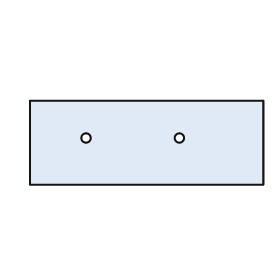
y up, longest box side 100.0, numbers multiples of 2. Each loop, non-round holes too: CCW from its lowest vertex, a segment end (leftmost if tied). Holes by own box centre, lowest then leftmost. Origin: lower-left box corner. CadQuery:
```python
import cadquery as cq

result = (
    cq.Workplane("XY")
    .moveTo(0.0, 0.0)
    .lineTo(100.0, 0.0)
    .lineTo(100.0, 36.0)
    .lineTo(0.0, 36.0)
    .close()
    .moveTo(24.0, 20.0)
    .circle(2.0)
    .moveTo(64.0, 20.0)
    .circle(2.0)
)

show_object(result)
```